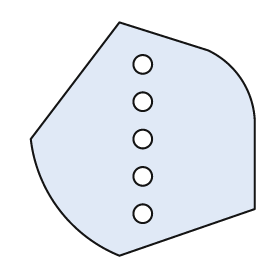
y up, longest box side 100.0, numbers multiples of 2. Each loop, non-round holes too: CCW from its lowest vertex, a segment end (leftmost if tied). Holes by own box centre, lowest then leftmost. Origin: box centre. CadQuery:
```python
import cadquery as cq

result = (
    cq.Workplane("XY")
    .moveTo(-10.0, -50.0)
    .lineTo(48.0, -30.0)
    .lineTo(48.0, 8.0)
    .threePointArc((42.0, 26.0), (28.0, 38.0))
    .lineTo(-10.0, 50.0)
    .lineTo(-48.0, 0.0)
    .threePointArc((-36.0, -30.0), (-10.0, -50.0))
    .close()
    .moveTo(0.0, -32.0)
    .circle(4.0)
    .moveTo(0.0, -16.0)
    .circle(4.0)
    .moveTo(0.0, 0.0)
    .circle(4.0)
    .moveTo(0.0, 16.0)
    .circle(4.0)
    .moveTo(0.0, 32.0)
    .circle(4.0)
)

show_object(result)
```